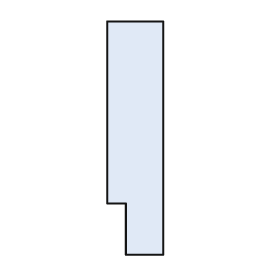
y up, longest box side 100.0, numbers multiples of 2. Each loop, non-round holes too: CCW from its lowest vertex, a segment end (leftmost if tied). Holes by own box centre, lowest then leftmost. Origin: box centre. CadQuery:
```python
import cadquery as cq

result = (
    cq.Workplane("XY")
    .moveTo(-4.0, -50.0)
    .lineTo(12.0, -50.0)
    .lineTo(12.0, 50.0)
    .lineTo(-12.0, 50.0)
    .lineTo(-12.0, -28.0)
    .lineTo(-4.0, -28.0)
    .close()
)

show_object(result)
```